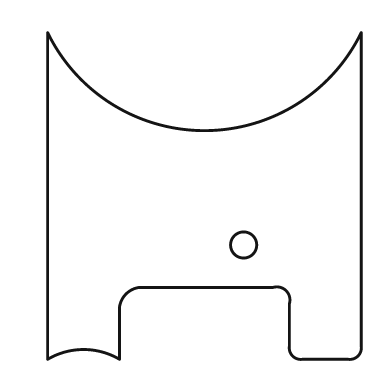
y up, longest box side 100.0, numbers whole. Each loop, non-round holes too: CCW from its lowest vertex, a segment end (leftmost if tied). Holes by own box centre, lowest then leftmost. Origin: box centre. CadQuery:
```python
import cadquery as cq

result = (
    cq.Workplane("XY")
    .moveTo(-48.0, -50.0)
    .threePointArc((-37.0, -47.0), (-26.0, -50.0))
    .lineTo(-26.0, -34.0)
    .threePointArc((-24.0, -30.0), (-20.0, -28.0))
    .lineTo(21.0, -28.0)
    .threePointArc((25.0, -29.0), (26.0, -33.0))
    .lineTo(26.0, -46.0)
    .threePointArc((27.0, -49.0), (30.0, -50.0))
    .lineTo(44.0, -50.0)
    .threePointArc((47.0, -49.0), (48.0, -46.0))
    .lineTo(48.0, 50.0)
    .threePointArc((0.0, 20.0), (-48.0, 50.0))
    .close()
    .moveTo(12.0, -15.0)
    .circle(4.0)
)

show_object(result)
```